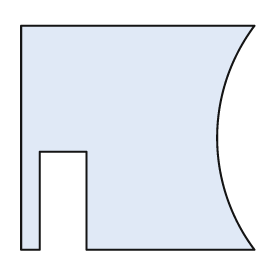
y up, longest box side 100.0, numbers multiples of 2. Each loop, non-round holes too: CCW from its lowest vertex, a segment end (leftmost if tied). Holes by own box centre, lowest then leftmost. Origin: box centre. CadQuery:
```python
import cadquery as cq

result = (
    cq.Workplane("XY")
    .moveTo(-50.0, -48.0)
    .lineTo(-42.0, -48.0)
    .lineTo(-42.0, -6.0)
    .lineTo(-22.0, -6.0)
    .lineTo(-22.0, -48.0)
    .lineTo(50.0, -48.0)
    .threePointArc((34.0, 0.0), (50.0, 48.0))
    .lineTo(-50.0, 48.0)
    .close()
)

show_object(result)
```